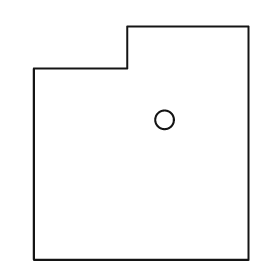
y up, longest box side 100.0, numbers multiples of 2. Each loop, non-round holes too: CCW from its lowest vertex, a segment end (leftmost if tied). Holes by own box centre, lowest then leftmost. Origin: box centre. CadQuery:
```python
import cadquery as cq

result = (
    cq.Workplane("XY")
    .moveTo(-46.0, -50.0)
    .lineTo(46.0, -50.0)
    .lineTo(46.0, 50.0)
    .lineTo(-6.0, 50.0)
    .lineTo(-6.0, 32.0)
    .lineTo(-46.0, 32.0)
    .close()
    .moveTo(10.0, 10.0)
    .circle(4.0)
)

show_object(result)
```